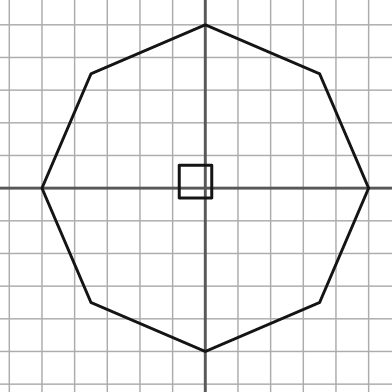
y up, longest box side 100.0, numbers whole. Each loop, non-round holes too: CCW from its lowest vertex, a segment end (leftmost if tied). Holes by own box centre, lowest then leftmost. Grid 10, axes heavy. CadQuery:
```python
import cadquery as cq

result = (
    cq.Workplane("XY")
    .moveTo(0.0, -50.0)
    .lineTo(35.0, -35.0)
    .lineTo(50.0, 0.0)
    .lineTo(35.0, 35.0)
    .lineTo(0.0, 50.0)
    .lineTo(-35.0, 35.0)
    .lineTo(-50.0, 0.0)
    .lineTo(-35.0, -35.0)
    .close()
    .moveTo(-8.0, -3.0)
    .lineTo(2.0, -3.0)
    .lineTo(2.0, 7.0)
    .lineTo(-8.0, 7.0)
    .close()
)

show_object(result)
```